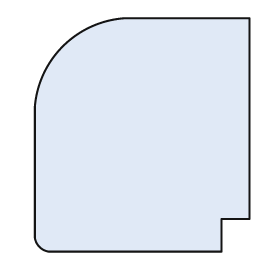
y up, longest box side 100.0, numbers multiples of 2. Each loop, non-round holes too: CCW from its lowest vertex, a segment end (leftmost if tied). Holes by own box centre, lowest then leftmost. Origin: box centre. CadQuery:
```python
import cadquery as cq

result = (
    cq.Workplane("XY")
    .moveTo(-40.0, -50.0)
    .lineTo(34.0, -50.0)
    .lineTo(34.0, -36.0)
    .lineTo(46.0, -36.0)
    .lineTo(46.0, 50.0)
    .lineTo(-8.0, 50.0)
    .threePointArc((-34.0, 38.0), (-46.0, 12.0))
    .lineTo(-46.0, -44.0)
    .threePointArc((-44.0, -48.0), (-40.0, -50.0))
    .close()
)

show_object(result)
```